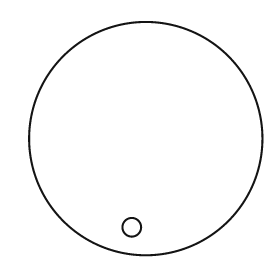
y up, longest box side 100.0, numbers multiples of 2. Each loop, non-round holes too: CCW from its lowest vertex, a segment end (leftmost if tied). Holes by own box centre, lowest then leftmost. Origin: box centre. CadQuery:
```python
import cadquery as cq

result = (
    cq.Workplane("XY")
    .moveTo(0.0, 0.0)
    .circle(50.0)
    .moveTo(-6.0, -38.0)
    .circle(4.0)
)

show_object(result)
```